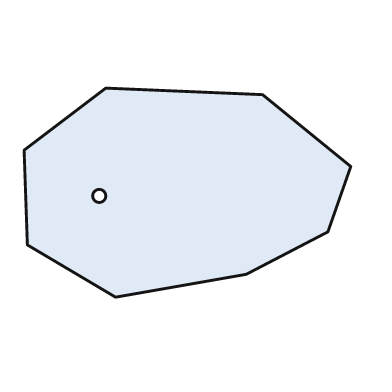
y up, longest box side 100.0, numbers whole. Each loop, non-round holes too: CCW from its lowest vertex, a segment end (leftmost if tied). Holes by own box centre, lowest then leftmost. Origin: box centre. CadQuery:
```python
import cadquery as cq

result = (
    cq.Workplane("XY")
    .moveTo(-22.0, -32.0)
    .lineTo(18.0, -25.0)
    .lineTo(43.0, -12.0)
    .lineTo(50.0, 8.0)
    .lineTo(23.0, 30.0)
    .lineTo(-25.0, 32.0)
    .lineTo(-50.0, 13.0)
    .lineTo(-49.0, -16.0)
    .close()
    .moveTo(-27.0, -1.0)
    .circle(2.0)
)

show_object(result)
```